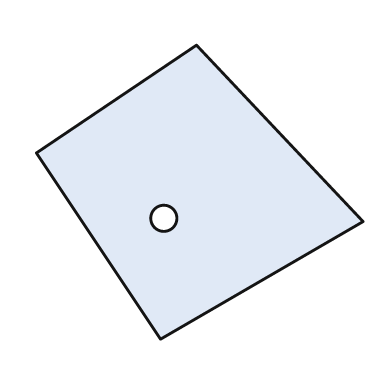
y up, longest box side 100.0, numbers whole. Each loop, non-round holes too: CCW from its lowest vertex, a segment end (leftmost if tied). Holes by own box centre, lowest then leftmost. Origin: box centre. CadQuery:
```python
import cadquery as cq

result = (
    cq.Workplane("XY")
    .moveTo(-12.0, -45.0)
    .lineTo(50.0, -9.0)
    .lineTo(-1.0, 45.0)
    .lineTo(-50.0, 12.0)
    .close()
    .moveTo(-11.0, -8.0)
    .circle(4.0)
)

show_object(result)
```